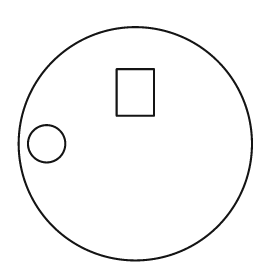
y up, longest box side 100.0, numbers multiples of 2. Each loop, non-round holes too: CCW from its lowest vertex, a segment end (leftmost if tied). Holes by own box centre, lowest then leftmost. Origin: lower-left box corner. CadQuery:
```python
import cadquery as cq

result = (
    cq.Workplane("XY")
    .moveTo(50.0, 50.0)
    .circle(50.0)
    .moveTo(12.0, 50.0)
    .circle(8.0)
    .moveTo(42.0, 62.0)
    .lineTo(58.0, 62.0)
    .lineTo(58.0, 82.0)
    .lineTo(42.0, 82.0)
    .close()
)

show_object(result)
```